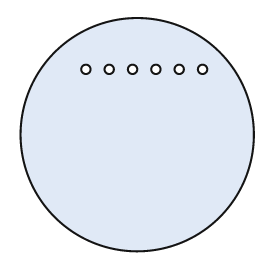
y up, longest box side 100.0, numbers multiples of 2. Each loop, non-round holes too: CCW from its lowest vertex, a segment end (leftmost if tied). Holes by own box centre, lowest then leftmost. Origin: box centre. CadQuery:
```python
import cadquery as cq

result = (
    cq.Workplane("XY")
    .moveTo(0.0, 0.0)
    .circle(50.0)
    .moveTo(-22.0, 28.0)
    .circle(2.0)
    .moveTo(-12.0, 28.0)
    .circle(2.0)
    .moveTo(-2.0, 28.0)
    .circle(2.0)
    .moveTo(8.0, 28.0)
    .circle(2.0)
    .moveTo(18.0, 28.0)
    .circle(2.0)
    .moveTo(28.0, 28.0)
    .circle(2.0)
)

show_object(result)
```